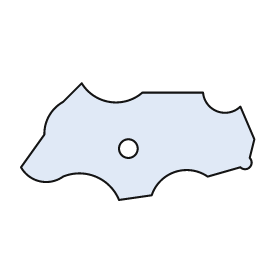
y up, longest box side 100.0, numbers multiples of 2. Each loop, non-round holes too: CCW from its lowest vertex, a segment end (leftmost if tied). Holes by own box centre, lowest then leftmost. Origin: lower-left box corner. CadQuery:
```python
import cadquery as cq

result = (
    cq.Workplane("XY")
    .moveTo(42.0, 0.0)
    .lineTo(56.0, 2.0)
    .threePointArc((66.0, 12.0), (80.0, 10.0))
    .lineTo(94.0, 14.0)
    .threePointArc((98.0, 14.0), (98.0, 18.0))
    .lineTo(100.0, 26.0)
    .lineTo(94.0, 40.0)
    .threePointArc((84.0, 38.0), (78.0, 46.0))
    .lineTo(52.0, 46.0)
    .threePointArc((38.0, 42.0), (26.0, 50.0))
    .lineTo(18.0, 42.0)
    .threePointArc((12.0, 36.0), (10.0, 28.0))
    .lineTo(0.0, 14.0)
    .threePointArc((8.0, 8.0), (18.0, 10.0))
    .threePointArc((32.0, 10.0), (42.0, 0.0))
    .close()
    .moveTo(46.0, 22.0)
    .circle(4.0)
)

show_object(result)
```